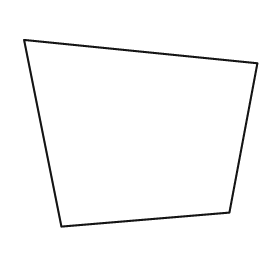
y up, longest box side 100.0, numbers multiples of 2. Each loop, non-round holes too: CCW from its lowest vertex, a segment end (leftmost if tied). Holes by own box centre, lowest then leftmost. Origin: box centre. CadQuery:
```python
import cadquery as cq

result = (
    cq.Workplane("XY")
    .moveTo(-34.0, -40.0)
    .lineTo(38.0, -34.0)
    .lineTo(50.0, 30.0)
    .lineTo(-50.0, 40.0)
    .close()
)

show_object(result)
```